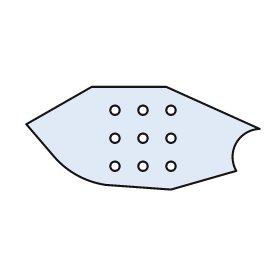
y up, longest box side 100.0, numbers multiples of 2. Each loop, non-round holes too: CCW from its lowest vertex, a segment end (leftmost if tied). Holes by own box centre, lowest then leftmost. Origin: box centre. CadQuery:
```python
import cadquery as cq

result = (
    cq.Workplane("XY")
    .moveTo(12.0, -22.0)
    .lineTo(40.0, -14.0)
    .threePointArc((40.0, -2.0), (50.0, 4.0))
    .lineTo(10.0, 22.0)
    .lineTo(-22.0, 22.0)
    .lineTo(-50.0, 6.0)
    .lineTo(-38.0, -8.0)
    .threePointArc((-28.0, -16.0), (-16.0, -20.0))
    .close()
    .moveTo(-12.0, -12.0)
    .circle(2.0)
    .moveTo(0.0, -12.0)
    .circle(2.0)
    .moveTo(12.0, -12.0)
    .circle(2.0)
    .moveTo(-12.0, 0.0)
    .circle(2.0)
    .moveTo(0.0, 0.0)
    .circle(2.0)
    .moveTo(12.0, 0.0)
    .circle(2.0)
    .moveTo(-12.0, 12.0)
    .circle(2.0)
    .moveTo(0.0, 12.0)
    .circle(2.0)
    .moveTo(12.0, 12.0)
    .circle(2.0)
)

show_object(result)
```